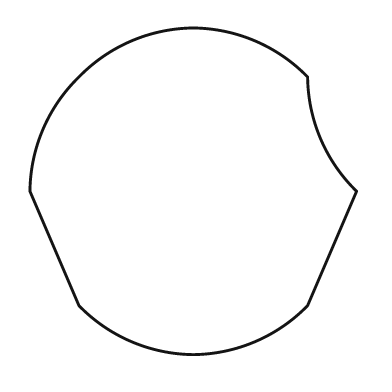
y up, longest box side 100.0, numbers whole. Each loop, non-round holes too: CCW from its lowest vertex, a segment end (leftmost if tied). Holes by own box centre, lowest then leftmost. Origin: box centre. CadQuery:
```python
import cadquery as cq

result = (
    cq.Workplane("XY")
    .moveTo(0.0, -50.0)
    .threePointArc((19.0, -46.0), (35.0, -35.0))
    .lineTo(50.0, 0.0)
    .threePointArc((39.0, 16.0), (35.0, 35.0))
    .threePointArc((19.0, 46.0), (0.0, 50.0))
    .threePointArc((-19.0, 46.0), (-35.0, 35.0))
    .threePointArc((-46.0, 19.0), (-50.0, 0.0))
    .lineTo(-35.0, -35.0)
    .threePointArc((-19.0, -46.0), (0.0, -50.0))
    .close()
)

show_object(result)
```